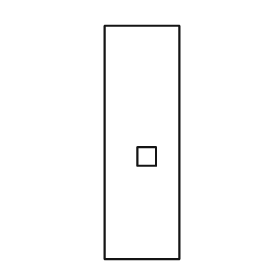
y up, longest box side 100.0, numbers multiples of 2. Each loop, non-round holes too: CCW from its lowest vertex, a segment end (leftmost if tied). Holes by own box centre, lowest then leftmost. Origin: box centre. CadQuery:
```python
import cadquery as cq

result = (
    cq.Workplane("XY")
    .moveTo(-16.0, -50.0)
    .lineTo(16.0, -50.0)
    .lineTo(16.0, 50.0)
    .lineTo(-16.0, 50.0)
    .close()
    .moveTo(-2.0, -10.0)
    .lineTo(6.0, -10.0)
    .lineTo(6.0, -2.0)
    .lineTo(-2.0, -2.0)
    .close()
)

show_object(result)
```